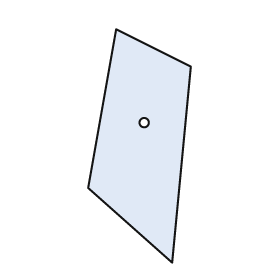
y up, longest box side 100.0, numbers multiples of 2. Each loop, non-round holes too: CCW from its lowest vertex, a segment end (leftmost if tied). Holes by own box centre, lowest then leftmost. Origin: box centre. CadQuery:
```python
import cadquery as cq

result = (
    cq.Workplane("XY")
    .moveTo(14.0, -50.0)
    .lineTo(22.0, 34.0)
    .lineTo(-10.0, 50.0)
    .lineTo(-22.0, -18.0)
    .close()
    .moveTo(2.0, 10.0)
    .circle(2.0)
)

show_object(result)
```